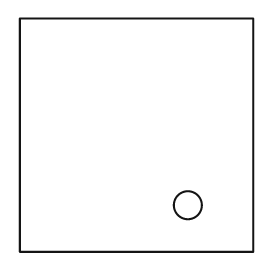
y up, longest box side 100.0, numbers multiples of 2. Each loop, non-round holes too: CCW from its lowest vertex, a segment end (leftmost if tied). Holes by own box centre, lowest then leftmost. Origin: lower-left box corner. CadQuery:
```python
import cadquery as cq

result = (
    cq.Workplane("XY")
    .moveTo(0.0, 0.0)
    .lineTo(100.0, 0.0)
    .lineTo(100.0, 100.0)
    .lineTo(0.0, 100.0)
    .close()
    .moveTo(72.0, 20.0)
    .circle(6.0)
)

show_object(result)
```